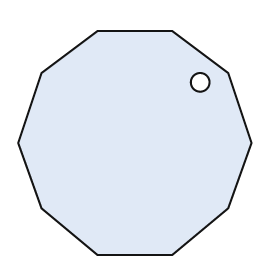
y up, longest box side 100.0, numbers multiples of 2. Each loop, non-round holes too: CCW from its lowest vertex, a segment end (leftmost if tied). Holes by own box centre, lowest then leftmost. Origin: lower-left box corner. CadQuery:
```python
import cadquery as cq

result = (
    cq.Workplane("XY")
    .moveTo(34.0, 0.0)
    .lineTo(66.0, 0.0)
    .lineTo(90.0, 20.0)
    .lineTo(100.0, 48.0)
    .lineTo(90.0, 78.0)
    .lineTo(66.0, 96.0)
    .lineTo(34.0, 96.0)
    .lineTo(10.0, 78.0)
    .lineTo(0.0, 48.0)
    .lineTo(10.0, 20.0)
    .close()
    .moveTo(78.0, 74.0)
    .circle(4.0)
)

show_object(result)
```